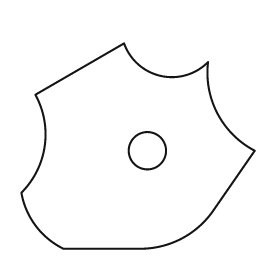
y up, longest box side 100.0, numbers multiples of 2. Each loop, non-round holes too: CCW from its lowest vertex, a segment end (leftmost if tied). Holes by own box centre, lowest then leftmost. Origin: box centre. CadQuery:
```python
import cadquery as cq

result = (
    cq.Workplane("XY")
    .moveTo(-32.0, -44.0)
    .lineTo(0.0, -44.0)
    .threePointArc((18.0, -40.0), (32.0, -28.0))
    .lineTo(50.0, -2.0)
    .threePointArc((34.0, 14.0), (30.0, 36.0))
    .threePointArc((10.0, 30.0), (-6.0, 44.0))
    .lineTo(-44.0, 22.0)
    .threePointArc((-40.0, 0.0), (-50.0, -20.0))
    .threePointArc((-44.0, -34.0), (-32.0, -44.0))
    .close()
    .moveTo(4.0, -2.0)
    .circle(8.0)
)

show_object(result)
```